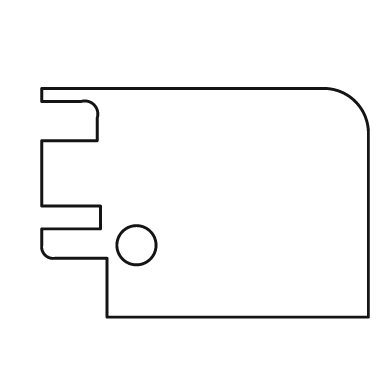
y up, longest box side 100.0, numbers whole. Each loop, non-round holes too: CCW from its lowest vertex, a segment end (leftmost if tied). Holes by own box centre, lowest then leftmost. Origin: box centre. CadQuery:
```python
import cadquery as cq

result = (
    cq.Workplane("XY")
    .moveTo(-30.0, -35.0)
    .lineTo(50.0, -35.0)
    .lineTo(50.0, 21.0)
    .threePointArc((46.0, 31.0), (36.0, 35.0))
    .lineTo(-50.0, 35.0)
    .lineTo(-50.0, 31.0)
    .lineTo(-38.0, 31.0)
    .threePointArc((-34.0, 30.0), (-33.0, 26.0))
    .lineTo(-33.0, 19.0)
    .lineTo(-50.0, 19.0)
    .lineTo(-50.0, -1.0)
    .lineTo(-32.0, -1.0)
    .lineTo(-32.0, -8.0)
    .lineTo(-50.0, -8.0)
    .lineTo(-50.0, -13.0)
    .threePointArc((-49.0, -16.0), (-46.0, -17.0))
    .lineTo(-30.0, -17.0)
    .close()
    .moveTo(-21.0, -13.0)
    .circle(6.0)
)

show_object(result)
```